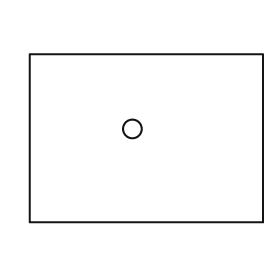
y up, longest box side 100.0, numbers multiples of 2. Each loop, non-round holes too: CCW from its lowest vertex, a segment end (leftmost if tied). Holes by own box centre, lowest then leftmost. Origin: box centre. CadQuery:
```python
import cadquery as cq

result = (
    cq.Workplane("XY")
    .moveTo(-50.0, -36.0)
    .lineTo(50.0, -36.0)
    .lineTo(50.0, 36.0)
    .lineTo(-50.0, 36.0)
    .close()
    .moveTo(-6.0, 4.0)
    .circle(4.0)
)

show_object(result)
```